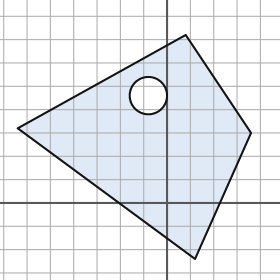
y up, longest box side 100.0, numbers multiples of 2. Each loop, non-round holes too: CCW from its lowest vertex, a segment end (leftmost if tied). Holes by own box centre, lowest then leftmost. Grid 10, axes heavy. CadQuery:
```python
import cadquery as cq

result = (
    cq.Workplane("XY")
    .moveTo(12.0, -24.0)
    .lineTo(36.0, 30.0)
    .lineTo(8.0, 72.0)
    .lineTo(-64.0, 32.0)
    .close()
    .moveTo(-8.0, 46.0)
    .circle(8.0)
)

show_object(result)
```